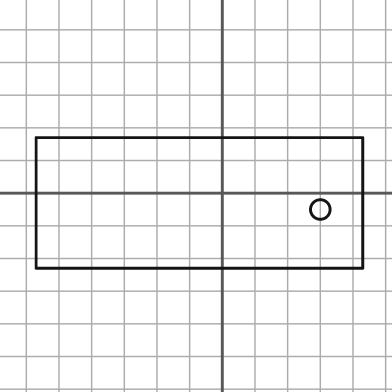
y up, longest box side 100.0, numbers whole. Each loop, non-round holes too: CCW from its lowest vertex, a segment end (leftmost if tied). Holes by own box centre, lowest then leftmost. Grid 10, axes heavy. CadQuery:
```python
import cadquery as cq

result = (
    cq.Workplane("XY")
    .moveTo(-57.0, -23.0)
    .lineTo(43.0, -23.0)
    .lineTo(43.0, 17.0)
    .lineTo(-57.0, 17.0)
    .close()
    .moveTo(30.0, -5.0)
    .circle(3.0)
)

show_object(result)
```